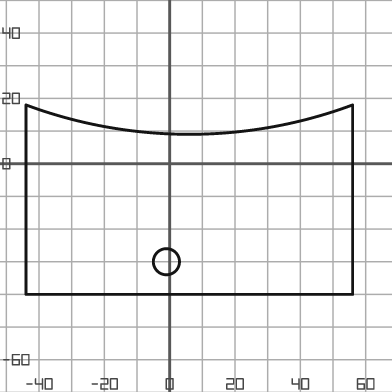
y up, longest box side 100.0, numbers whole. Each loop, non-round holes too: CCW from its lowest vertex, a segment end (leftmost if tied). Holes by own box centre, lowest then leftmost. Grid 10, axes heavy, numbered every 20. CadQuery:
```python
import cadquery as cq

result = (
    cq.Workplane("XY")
    .moveTo(-44.0, -40.0)
    .lineTo(56.0, -40.0)
    .lineTo(56.0, 18.0)
    .threePointArc((6.0, 9.0), (-44.0, 18.0))
    .close()
    .moveTo(-1.0, -30.0)
    .circle(4.0)
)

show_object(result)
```